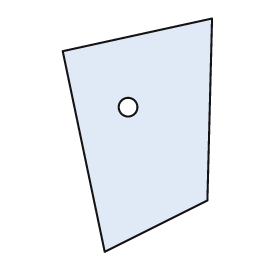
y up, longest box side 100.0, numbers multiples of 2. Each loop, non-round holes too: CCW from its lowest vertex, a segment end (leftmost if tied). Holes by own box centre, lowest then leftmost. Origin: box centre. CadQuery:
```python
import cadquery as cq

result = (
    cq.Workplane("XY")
    .moveTo(-14.0, -50.0)
    .lineTo(30.0, -28.0)
    .lineTo(32.0, 50.0)
    .lineTo(-32.0, 36.0)
    .close()
    .moveTo(-4.0, 12.0)
    .circle(4.0)
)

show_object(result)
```